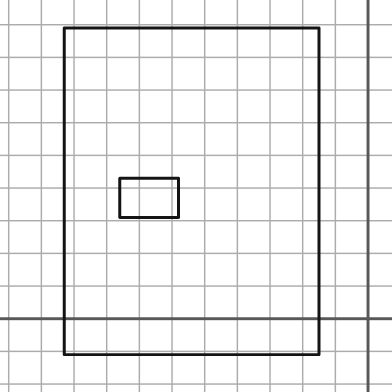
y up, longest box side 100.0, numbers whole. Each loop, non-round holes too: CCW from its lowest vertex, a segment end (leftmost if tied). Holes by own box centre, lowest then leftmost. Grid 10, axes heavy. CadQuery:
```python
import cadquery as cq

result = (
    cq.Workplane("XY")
    .moveTo(-93.0, -11.0)
    .lineTo(-15.0, -11.0)
    .lineTo(-15.0, 89.0)
    .lineTo(-93.0, 89.0)
    .close()
    .moveTo(-76.0, 31.0)
    .lineTo(-58.0, 31.0)
    .lineTo(-58.0, 43.0)
    .lineTo(-76.0, 43.0)
    .close()
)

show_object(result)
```